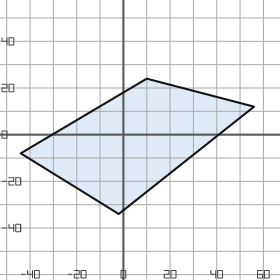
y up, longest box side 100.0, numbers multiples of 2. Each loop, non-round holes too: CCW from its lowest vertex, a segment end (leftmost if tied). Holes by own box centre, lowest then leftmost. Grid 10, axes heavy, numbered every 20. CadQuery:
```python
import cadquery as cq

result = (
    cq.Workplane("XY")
    .moveTo(-2.0, -34.0)
    .lineTo(56.0, 12.0)
    .lineTo(10.0, 24.0)
    .lineTo(-44.0, -8.0)
    .close()
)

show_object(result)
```